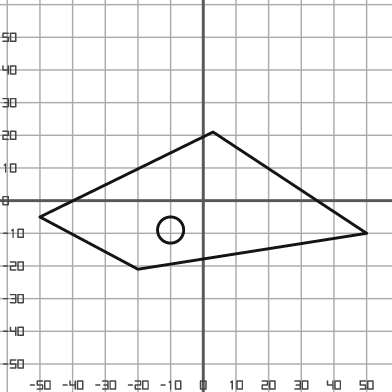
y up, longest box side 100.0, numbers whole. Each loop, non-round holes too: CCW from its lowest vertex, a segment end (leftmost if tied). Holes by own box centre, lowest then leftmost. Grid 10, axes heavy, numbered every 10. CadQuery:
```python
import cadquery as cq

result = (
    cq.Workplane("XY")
    .moveTo(-20.0, -21.0)
    .lineTo(50.0, -10.0)
    .lineTo(3.0, 21.0)
    .lineTo(-50.0, -5.0)
    .close()
    .moveTo(-10.0, -9.0)
    .circle(4.0)
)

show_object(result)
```